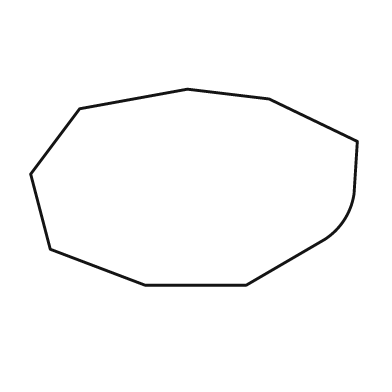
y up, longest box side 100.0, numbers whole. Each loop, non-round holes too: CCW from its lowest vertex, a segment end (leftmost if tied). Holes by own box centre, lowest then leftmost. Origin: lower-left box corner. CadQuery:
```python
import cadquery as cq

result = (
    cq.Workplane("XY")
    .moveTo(35.0, 0.0)
    .lineTo(66.0, 0.0)
    .lineTo(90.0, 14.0)
    .threePointArc((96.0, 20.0), (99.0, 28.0))
    .lineTo(100.0, 44.0)
    .lineTo(73.0, 57.0)
    .lineTo(48.0, 60.0)
    .lineTo(15.0, 54.0)
    .lineTo(0.0, 34.0)
    .lineTo(6.0, 11.0)
    .close()
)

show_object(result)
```